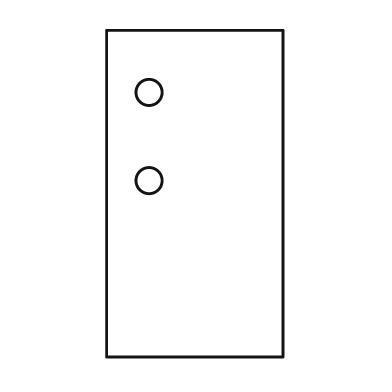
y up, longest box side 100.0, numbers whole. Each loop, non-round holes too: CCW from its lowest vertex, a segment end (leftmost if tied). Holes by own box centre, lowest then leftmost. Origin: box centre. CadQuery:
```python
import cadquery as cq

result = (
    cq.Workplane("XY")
    .moveTo(-27.0, -50.0)
    .lineTo(27.0, -50.0)
    .lineTo(27.0, 50.0)
    .lineTo(-27.0, 50.0)
    .close()
    .moveTo(-14.0, 4.0)
    .circle(4.0)
    .moveTo(-14.0, 31.0)
    .circle(4.0)
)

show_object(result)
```